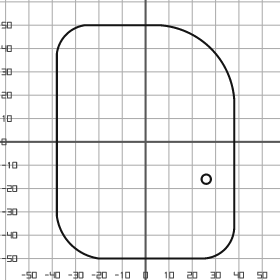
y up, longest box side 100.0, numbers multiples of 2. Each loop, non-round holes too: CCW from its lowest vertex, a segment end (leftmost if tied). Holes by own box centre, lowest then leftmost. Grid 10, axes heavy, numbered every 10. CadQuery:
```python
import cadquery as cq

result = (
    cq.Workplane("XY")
    .moveTo(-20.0, -50.0)
    .lineTo(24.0, -50.0)
    .threePointArc((34.0, -46.0), (38.0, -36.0))
    .lineTo(38.0, 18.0)
    .threePointArc((28.0, 40.0), (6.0, 50.0))
    .lineTo(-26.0, 50.0)
    .threePointArc((-34.0, 46.0), (-38.0, 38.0))
    .lineTo(-38.0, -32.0)
    .threePointArc((-32.0, -44.0), (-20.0, -50.0))
    .close()
    .moveTo(26.0, -16.0)
    .circle(2.0)
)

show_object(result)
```